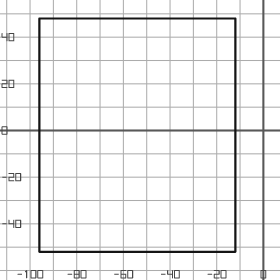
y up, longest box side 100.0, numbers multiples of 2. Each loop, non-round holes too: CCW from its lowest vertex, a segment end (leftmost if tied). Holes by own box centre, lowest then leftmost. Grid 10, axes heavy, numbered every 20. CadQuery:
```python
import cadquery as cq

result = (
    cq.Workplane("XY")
    .moveTo(-96.0, -52.0)
    .lineTo(-12.0, -52.0)
    .lineTo(-12.0, 48.0)
    .lineTo(-96.0, 48.0)
    .close()
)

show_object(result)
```